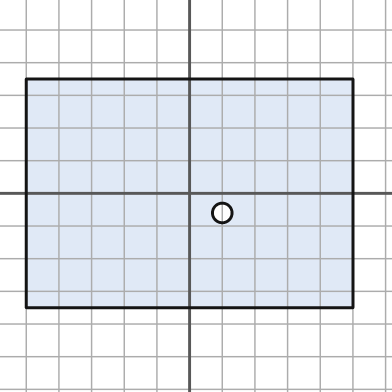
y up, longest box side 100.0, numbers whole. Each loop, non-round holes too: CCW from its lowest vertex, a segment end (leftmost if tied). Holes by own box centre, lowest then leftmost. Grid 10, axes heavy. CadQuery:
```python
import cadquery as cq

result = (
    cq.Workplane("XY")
    .moveTo(-50.0, -35.0)
    .lineTo(50.0, -35.0)
    .lineTo(50.0, 35.0)
    .lineTo(-50.0, 35.0)
    .close()
    .moveTo(10.0, -6.0)
    .circle(3.0)
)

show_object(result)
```